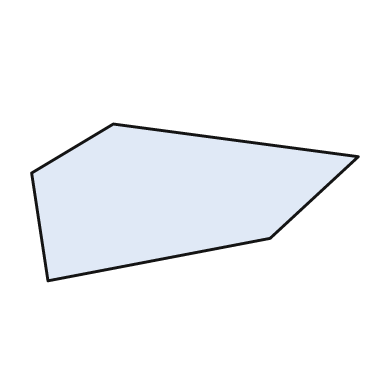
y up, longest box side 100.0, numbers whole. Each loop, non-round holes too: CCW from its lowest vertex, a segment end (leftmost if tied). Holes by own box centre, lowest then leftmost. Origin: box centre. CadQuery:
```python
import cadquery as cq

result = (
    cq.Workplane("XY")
    .moveTo(-45.0, -24.0)
    .lineTo(23.0, -11.0)
    .lineTo(50.0, 14.0)
    .lineTo(-25.0, 24.0)
    .lineTo(-50.0, 9.0)
    .close()
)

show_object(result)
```